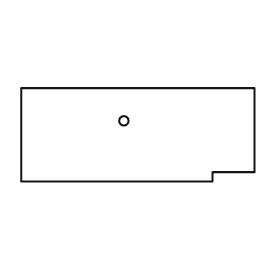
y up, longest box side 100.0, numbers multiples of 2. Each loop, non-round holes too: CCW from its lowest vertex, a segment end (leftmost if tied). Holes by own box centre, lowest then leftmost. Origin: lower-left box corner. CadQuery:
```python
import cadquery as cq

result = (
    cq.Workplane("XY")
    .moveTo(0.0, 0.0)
    .lineTo(82.0, 0.0)
    .lineTo(82.0, 4.0)
    .lineTo(100.0, 4.0)
    .lineTo(100.0, 40.0)
    .lineTo(0.0, 40.0)
    .close()
    .moveTo(44.0, 26.0)
    .circle(2.0)
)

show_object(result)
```